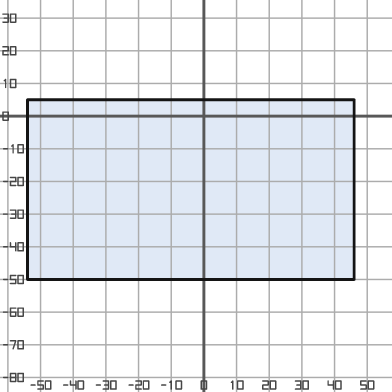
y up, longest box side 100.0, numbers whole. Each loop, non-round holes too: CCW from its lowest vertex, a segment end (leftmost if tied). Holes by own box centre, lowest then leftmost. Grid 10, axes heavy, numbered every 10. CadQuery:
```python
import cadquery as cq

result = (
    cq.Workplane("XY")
    .moveTo(-54.0, -50.0)
    .lineTo(46.0, -50.0)
    .lineTo(46.0, 5.0)
    .lineTo(-54.0, 5.0)
    .close()
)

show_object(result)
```